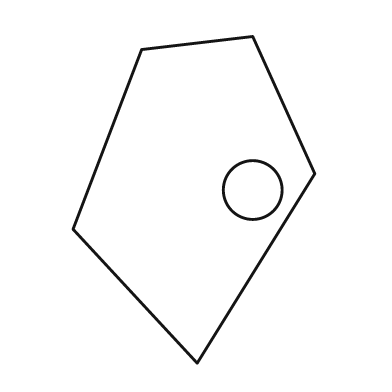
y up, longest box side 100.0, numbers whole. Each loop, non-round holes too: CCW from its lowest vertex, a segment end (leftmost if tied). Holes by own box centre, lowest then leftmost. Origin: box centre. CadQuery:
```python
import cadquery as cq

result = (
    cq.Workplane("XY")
    .moveTo(1.0, -50.0)
    .lineTo(37.0, 8.0)
    .lineTo(18.0, 50.0)
    .lineTo(-16.0, 46.0)
    .lineTo(-37.0, -9.0)
    .close()
    .moveTo(18.0, 3.0)
    .circle(9.0)
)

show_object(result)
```